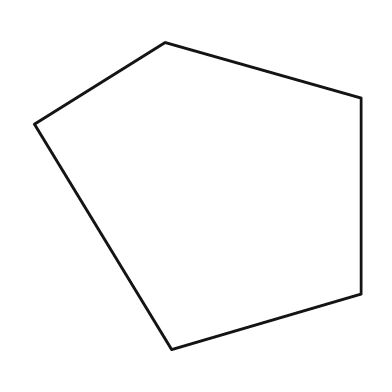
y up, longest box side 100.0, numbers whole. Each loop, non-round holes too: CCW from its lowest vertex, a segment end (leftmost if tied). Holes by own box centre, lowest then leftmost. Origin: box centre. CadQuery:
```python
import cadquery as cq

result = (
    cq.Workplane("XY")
    .moveTo(-8.0, -47.0)
    .lineTo(50.0, -30.0)
    .lineTo(50.0, 30.0)
    .lineTo(-10.0, 47.0)
    .lineTo(-50.0, 22.0)
    .close()
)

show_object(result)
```